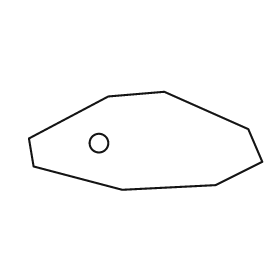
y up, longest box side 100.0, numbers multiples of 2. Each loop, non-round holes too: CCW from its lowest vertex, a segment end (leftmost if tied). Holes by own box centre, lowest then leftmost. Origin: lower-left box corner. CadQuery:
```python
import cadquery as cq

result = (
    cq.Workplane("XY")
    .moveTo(40.0, 0.0)
    .lineTo(80.0, 2.0)
    .lineTo(100.0, 12.0)
    .lineTo(94.0, 26.0)
    .lineTo(58.0, 42.0)
    .lineTo(34.0, 40.0)
    .lineTo(0.0, 22.0)
    .lineTo(2.0, 10.0)
    .close()
    .moveTo(30.0, 20.0)
    .circle(4.0)
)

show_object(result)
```